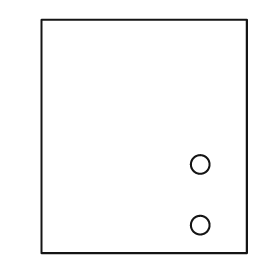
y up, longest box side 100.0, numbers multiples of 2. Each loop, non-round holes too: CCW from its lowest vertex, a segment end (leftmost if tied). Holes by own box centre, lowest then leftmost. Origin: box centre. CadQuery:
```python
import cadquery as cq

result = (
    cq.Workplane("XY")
    .moveTo(-44.0, -50.0)
    .lineTo(44.0, -50.0)
    .lineTo(44.0, 50.0)
    .lineTo(-44.0, 50.0)
    .close()
    .moveTo(24.0, -38.0)
    .circle(4.0)
    .moveTo(24.0, -12.0)
    .circle(4.0)
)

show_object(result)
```